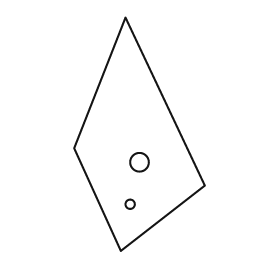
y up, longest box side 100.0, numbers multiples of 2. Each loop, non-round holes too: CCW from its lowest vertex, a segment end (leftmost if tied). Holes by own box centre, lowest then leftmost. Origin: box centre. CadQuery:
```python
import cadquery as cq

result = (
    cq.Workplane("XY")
    .moveTo(-8.0, -50.0)
    .lineTo(28.0, -22.0)
    .lineTo(-6.0, 50.0)
    .lineTo(-28.0, -6.0)
    .close()
    .moveTo(-4.0, -30.0)
    .circle(2.0)
    .moveTo(0.0, -12.0)
    .circle(4.0)
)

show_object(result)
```